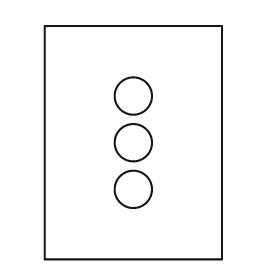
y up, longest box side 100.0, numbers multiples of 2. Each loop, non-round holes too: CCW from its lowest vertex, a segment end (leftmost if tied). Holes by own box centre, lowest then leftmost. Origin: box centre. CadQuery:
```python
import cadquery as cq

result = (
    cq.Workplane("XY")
    .moveTo(-38.0, -50.0)
    .lineTo(38.0, -50.0)
    .lineTo(38.0, 50.0)
    .lineTo(-38.0, 50.0)
    .close()
    .moveTo(0.0, -20.0)
    .circle(8.0)
    .moveTo(0.0, 0.0)
    .circle(8.0)
    .moveTo(0.0, 20.0)
    .circle(8.0)
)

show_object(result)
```